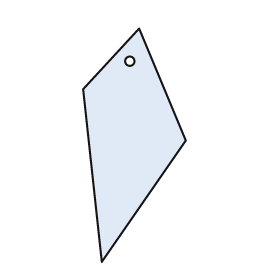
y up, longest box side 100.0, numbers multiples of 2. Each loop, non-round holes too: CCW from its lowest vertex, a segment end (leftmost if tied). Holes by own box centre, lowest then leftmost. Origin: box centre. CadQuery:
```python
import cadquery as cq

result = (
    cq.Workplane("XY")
    .moveTo(-14.0, -50.0)
    .lineTo(22.0, 2.0)
    .lineTo(2.0, 50.0)
    .lineTo(-22.0, 24.0)
    .close()
    .moveTo(-2.0, 36.0)
    .circle(2.0)
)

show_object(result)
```